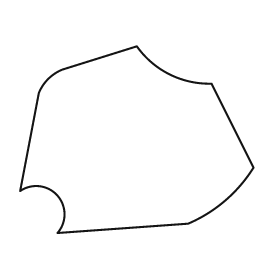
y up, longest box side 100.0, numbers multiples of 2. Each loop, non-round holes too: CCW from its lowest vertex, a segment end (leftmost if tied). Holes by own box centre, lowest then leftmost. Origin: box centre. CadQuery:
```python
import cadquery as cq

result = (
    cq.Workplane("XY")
    .moveTo(-34.0, -40.0)
    .lineTo(22.0, -36.0)
    .threePointArc((38.0, -26.0), (50.0, -12.0))
    .lineTo(32.0, 24.0)
    .threePointArc((14.0, 28.0), (0.0, 40.0))
    .lineTo(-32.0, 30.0)
    .threePointArc((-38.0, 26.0), (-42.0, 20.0))
    .lineTo(-50.0, -22.0)
    .threePointArc((-34.0, -24.0), (-34.0, -40.0))
    .close()
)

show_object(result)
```